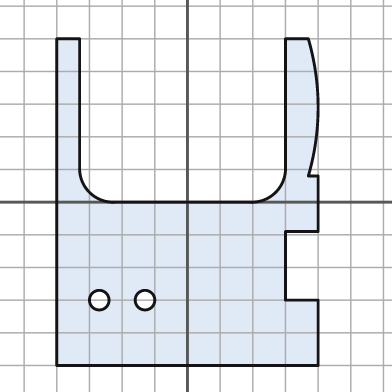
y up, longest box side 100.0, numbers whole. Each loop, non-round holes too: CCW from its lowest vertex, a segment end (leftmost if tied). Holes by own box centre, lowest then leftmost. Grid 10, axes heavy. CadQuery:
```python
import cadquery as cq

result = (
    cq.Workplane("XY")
    .moveTo(-40.0, -50.0)
    .lineTo(40.0, -50.0)
    .lineTo(40.0, -30.0)
    .lineTo(30.0, -30.0)
    .lineTo(30.0, -9.0)
    .lineTo(40.0, -9.0)
    .lineTo(40.0, 8.0)
    .lineTo(37.0, 8.0)
    .threePointArc((40.0, 29.0), (37.0, 50.0))
    .lineTo(30.0, 50.0)
    .lineTo(30.0, 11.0)
    .threePointArc((27.0, 3.0), (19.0, 0.0))
    .lineTo(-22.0, 0.0)
    .threePointArc((-30.0, 3.0), (-33.0, 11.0))
    .lineTo(-33.0, 50.0)
    .lineTo(-40.0, 50.0)
    .close()
    .moveTo(-27.0, -30.0)
    .circle(3.0)
    .moveTo(-13.0, -30.0)
    .circle(3.0)
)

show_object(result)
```